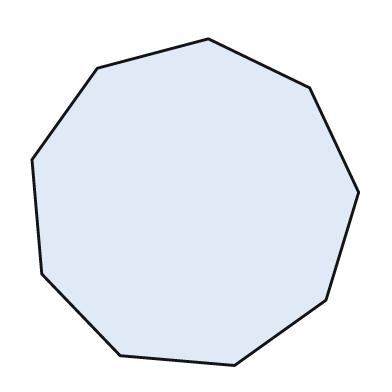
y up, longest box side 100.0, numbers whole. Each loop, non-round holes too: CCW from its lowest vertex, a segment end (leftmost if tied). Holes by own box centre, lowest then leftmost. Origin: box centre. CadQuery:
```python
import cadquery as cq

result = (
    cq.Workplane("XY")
    .moveTo(12.0, -50.0)
    .lineTo(40.0, -30.0)
    .lineTo(50.0, 3.0)
    .lineTo(35.0, 35.0)
    .lineTo(4.0, 50.0)
    .lineTo(-30.0, 41.0)
    .lineTo(-50.0, 13.0)
    .lineTo(-47.0, -22.0)
    .lineTo(-23.0, -47.0)
    .close()
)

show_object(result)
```